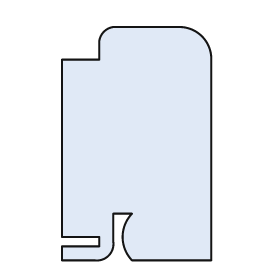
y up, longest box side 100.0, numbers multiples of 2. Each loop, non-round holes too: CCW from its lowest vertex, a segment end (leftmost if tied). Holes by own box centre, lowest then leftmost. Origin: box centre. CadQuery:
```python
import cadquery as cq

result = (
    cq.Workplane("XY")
    .moveTo(-32.0, -50.0)
    .lineTo(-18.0, -50.0)
    .threePointArc((-12.0, -48.0), (-10.0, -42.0))
    .lineTo(-10.0, -30.0)
    .lineTo(-2.0, -30.0)
    .threePointArc((-6.0, -40.0), (-2.0, -50.0))
    .lineTo(32.0, -50.0)
    .lineTo(32.0, 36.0)
    .threePointArc((28.0, 46.0), (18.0, 50.0))
    .lineTo(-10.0, 50.0)
    .threePointArc((-14.0, 48.0), (-16.0, 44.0))
    .lineTo(-16.0, 36.0)
    .lineTo(-32.0, 36.0)
    .lineTo(-32.0, -40.0)
    .lineTo(-16.0, -40.0)
    .lineTo(-16.0, -44.0)
    .lineTo(-32.0, -44.0)
    .close()
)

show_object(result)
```